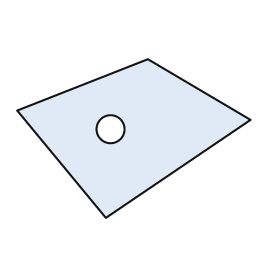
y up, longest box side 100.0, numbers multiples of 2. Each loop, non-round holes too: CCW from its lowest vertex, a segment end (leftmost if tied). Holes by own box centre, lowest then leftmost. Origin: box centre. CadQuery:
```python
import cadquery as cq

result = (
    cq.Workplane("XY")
    .moveTo(-12.0, -34.0)
    .lineTo(50.0, 8.0)
    .lineTo(6.0, 34.0)
    .lineTo(-50.0, 12.0)
    .close()
    .moveTo(-10.0, 4.0)
    .circle(6.0)
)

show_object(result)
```